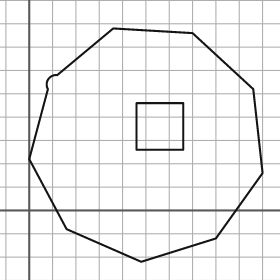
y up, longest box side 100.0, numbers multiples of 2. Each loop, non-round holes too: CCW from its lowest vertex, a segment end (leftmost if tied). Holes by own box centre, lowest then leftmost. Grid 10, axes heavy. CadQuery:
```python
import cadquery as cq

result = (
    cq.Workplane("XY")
    .moveTo(48.0, -22.0)
    .lineTo(80.0, -12.0)
    .lineTo(100.0, 16.0)
    .lineTo(96.0, 52.0)
    .lineTo(70.0, 76.0)
    .lineTo(36.0, 78.0)
    .lineTo(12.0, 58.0)
    .threePointArc((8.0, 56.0), (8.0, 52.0))
    .lineTo(0.0, 22.0)
    .lineTo(16.0, -8.0)
    .close()
    .moveTo(46.0, 26.0)
    .lineTo(66.0, 26.0)
    .lineTo(66.0, 46.0)
    .lineTo(46.0, 46.0)
    .close()
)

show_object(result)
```